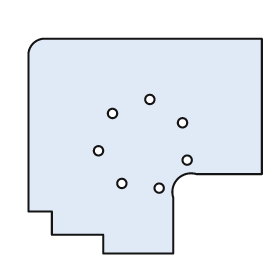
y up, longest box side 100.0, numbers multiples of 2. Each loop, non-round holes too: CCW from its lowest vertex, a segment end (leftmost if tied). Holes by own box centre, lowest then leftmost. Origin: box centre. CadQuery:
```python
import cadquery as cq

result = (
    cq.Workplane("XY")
    .moveTo(-18.0, -46.0)
    .lineTo(12.0, -46.0)
    .lineTo(12.0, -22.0)
    .threePointArc((14.0, -14.0), (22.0, -12.0))
    .lineTo(50.0, -12.0)
    .lineTo(50.0, 46.0)
    .lineTo(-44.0, 46.0)
    .threePointArc((-48.0, 44.0), (-50.0, 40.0))
    .lineTo(-50.0, -28.0)
    .lineTo(-40.0, -28.0)
    .lineTo(-40.0, -38.0)
    .lineTo(-18.0, -38.0)
    .close()
    .moveTo(6.0, -18.0)
    .circle(2.0)
    .moveTo(-10.0, -16.0)
    .circle(2.0)
    .moveTo(18.0, -6.0)
    .circle(2.0)
    .moveTo(-20.0, -2.0)
    .circle(2.0)
    .moveTo(16.0, 10.0)
    .circle(2.0)
    .moveTo(-14.0, 14.0)
    .circle(2.0)
    .moveTo(2.0, 20.0)
    .circle(2.0)
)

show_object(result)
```